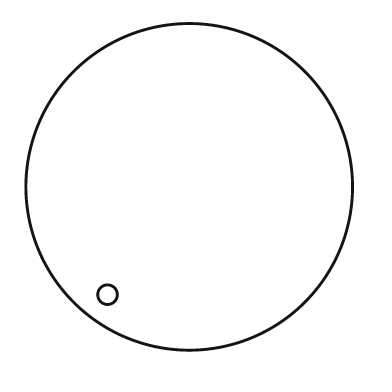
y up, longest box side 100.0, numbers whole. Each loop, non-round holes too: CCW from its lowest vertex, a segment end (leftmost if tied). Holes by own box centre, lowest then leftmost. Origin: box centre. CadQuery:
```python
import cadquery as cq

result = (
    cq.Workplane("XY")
    .moveTo(0.0, 0.0)
    .circle(50.0)
    .moveTo(-25.0, -33.0)
    .circle(3.0)
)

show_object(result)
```